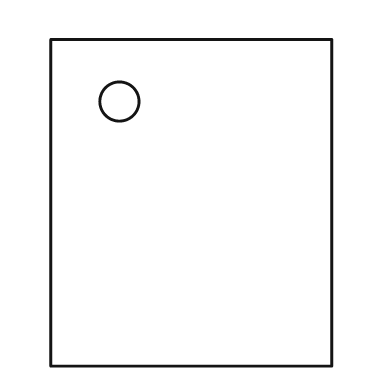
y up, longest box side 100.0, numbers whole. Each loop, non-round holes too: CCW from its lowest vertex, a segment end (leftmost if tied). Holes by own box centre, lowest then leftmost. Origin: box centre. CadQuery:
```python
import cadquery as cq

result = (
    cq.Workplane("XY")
    .moveTo(-43.0, -50.0)
    .lineTo(43.0, -50.0)
    .lineTo(43.0, 50.0)
    .lineTo(-43.0, 50.0)
    .close()
    .moveTo(-22.0, 31.0)
    .circle(6.0)
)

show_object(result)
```